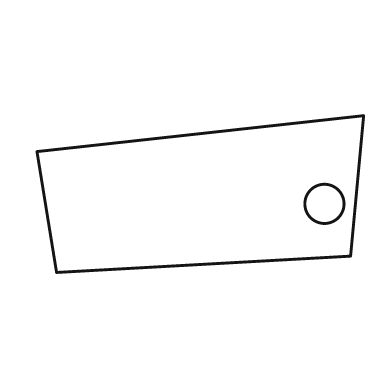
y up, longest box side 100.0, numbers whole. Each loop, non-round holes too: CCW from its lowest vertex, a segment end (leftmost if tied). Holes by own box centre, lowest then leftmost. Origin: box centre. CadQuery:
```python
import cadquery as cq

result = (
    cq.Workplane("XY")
    .moveTo(-44.0, -24.0)
    .lineTo(46.0, -19.0)
    .lineTo(50.0, 24.0)
    .lineTo(-50.0, 13.0)
    .close()
    .moveTo(38.0, -3.0)
    .circle(6.0)
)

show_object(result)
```